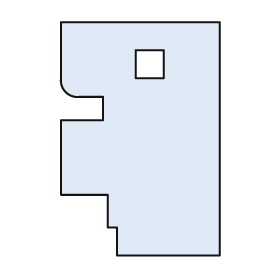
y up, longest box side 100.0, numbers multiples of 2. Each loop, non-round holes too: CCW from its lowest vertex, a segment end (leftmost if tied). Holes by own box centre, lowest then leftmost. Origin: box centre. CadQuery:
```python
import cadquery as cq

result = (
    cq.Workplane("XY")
    .moveTo(-10.0, -50.0)
    .lineTo(34.0, -50.0)
    .lineTo(34.0, 50.0)
    .lineTo(-34.0, 50.0)
    .lineTo(-34.0, 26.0)
    .threePointArc((-32.0, 20.0), (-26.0, 18.0))
    .lineTo(-16.0, 18.0)
    .lineTo(-16.0, 8.0)
    .lineTo(-34.0, 8.0)
    .lineTo(-34.0, -24.0)
    .lineTo(-14.0, -24.0)
    .lineTo(-14.0, -38.0)
    .lineTo(-10.0, -38.0)
    .close()
    .moveTo(-2.0, 26.0)
    .lineTo(10.0, 26.0)
    .lineTo(10.0, 38.0)
    .lineTo(-2.0, 38.0)
    .close()
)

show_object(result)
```